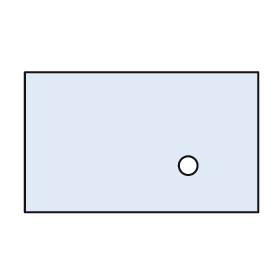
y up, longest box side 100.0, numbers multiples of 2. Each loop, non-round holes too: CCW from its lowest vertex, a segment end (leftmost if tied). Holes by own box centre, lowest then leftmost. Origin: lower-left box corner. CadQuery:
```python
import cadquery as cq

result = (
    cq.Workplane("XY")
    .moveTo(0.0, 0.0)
    .lineTo(100.0, 0.0)
    .lineTo(100.0, 60.0)
    .lineTo(0.0, 60.0)
    .close()
    .moveTo(70.0, 20.0)
    .circle(4.0)
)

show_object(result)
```